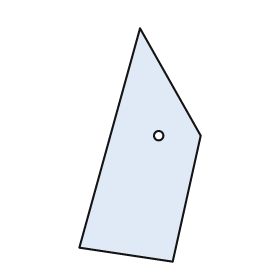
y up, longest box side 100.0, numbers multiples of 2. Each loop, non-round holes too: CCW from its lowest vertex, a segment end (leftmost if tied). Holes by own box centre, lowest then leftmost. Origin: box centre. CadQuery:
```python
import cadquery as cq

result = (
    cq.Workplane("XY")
    .moveTo(14.0, -50.0)
    .lineTo(26.0, 4.0)
    .lineTo(0.0, 50.0)
    .lineTo(-26.0, -44.0)
    .close()
    .moveTo(8.0, 4.0)
    .circle(2.0)
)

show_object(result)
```